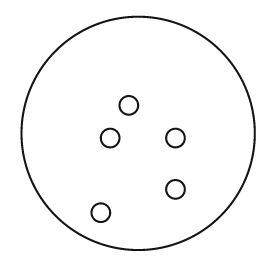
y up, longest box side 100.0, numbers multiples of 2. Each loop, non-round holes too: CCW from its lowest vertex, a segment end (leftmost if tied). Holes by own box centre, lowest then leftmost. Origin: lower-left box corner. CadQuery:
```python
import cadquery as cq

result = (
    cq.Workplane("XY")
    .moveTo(50.0, 50.0)
    .circle(50.0)
    .moveTo(34.0, 16.0)
    .circle(4.0)
    .moveTo(66.0, 26.0)
    .circle(4.0)
    .moveTo(38.0, 48.0)
    .circle(4.0)
    .moveTo(66.0, 48.0)
    .circle(4.0)
    .moveTo(46.0, 62.0)
    .circle(4.0)
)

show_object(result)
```